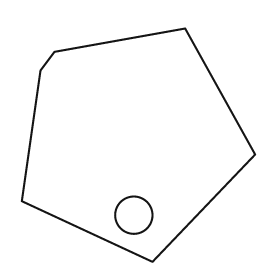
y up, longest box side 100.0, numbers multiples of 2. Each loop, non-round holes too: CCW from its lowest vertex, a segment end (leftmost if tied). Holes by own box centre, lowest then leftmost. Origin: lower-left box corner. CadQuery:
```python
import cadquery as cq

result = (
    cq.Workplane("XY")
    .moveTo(56.0, 0.0)
    .lineTo(100.0, 46.0)
    .lineTo(70.0, 100.0)
    .lineTo(14.0, 90.0)
    .lineTo(8.0, 82.0)
    .lineTo(0.0, 26.0)
    .close()
    .moveTo(48.0, 20.0)
    .circle(8.0)
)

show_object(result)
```